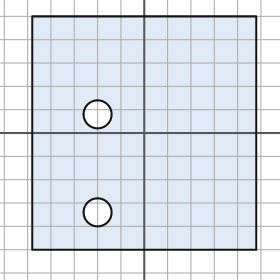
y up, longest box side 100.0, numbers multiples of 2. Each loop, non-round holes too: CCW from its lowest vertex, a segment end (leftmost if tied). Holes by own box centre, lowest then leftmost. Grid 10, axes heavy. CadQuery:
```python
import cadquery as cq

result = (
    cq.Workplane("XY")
    .moveTo(-48.0, -50.0)
    .lineTo(48.0, -50.0)
    .lineTo(48.0, 50.0)
    .lineTo(-48.0, 50.0)
    .close()
    .moveTo(-20.0, -34.0)
    .circle(6.0)
    .moveTo(-20.0, 8.0)
    .circle(6.0)
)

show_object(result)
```